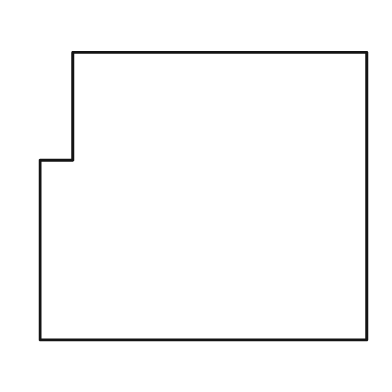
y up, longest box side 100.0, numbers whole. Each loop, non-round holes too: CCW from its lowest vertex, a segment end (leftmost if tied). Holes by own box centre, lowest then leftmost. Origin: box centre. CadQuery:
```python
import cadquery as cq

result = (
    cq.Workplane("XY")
    .moveTo(-50.0, -44.0)
    .lineTo(50.0, -44.0)
    .lineTo(50.0, 44.0)
    .lineTo(-40.0, 44.0)
    .lineTo(-40.0, 11.0)
    .lineTo(-50.0, 11.0)
    .close()
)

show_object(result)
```